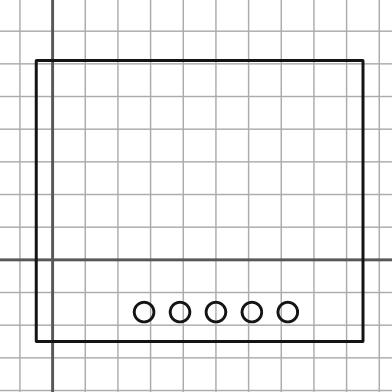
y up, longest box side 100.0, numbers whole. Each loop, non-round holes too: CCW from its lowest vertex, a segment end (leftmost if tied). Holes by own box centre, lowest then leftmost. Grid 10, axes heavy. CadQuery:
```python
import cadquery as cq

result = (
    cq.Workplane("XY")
    .moveTo(-5.0, -25.0)
    .lineTo(95.0, -25.0)
    .lineTo(95.0, 61.0)
    .lineTo(-5.0, 61.0)
    .close()
    .moveTo(28.0, -16.0)
    .circle(3.0)
    .moveTo(39.0, -16.0)
    .circle(3.0)
    .moveTo(50.0, -16.0)
    .circle(3.0)
    .moveTo(61.0, -16.0)
    .circle(3.0)
    .moveTo(72.0, -16.0)
    .circle(3.0)
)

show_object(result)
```